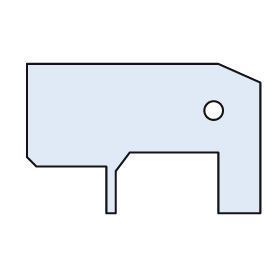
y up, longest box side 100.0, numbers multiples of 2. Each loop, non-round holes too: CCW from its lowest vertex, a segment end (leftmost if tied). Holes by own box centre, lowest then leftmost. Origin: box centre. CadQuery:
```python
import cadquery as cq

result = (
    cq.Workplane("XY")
    .moveTo(-16.0, -32.0)
    .lineTo(-12.0, -32.0)
    .lineTo(-12.0, -14.0)
    .lineTo(-6.0, -6.0)
    .lineTo(32.0, -6.0)
    .lineTo(32.0, -32.0)
    .lineTo(50.0, -32.0)
    .lineTo(50.0, 24.0)
    .lineTo(32.0, 32.0)
    .lineTo(-50.0, 32.0)
    .lineTo(-50.0, -8.0)
    .lineTo(-46.0, -12.0)
    .lineTo(-16.0, -12.0)
    .close()
    .moveTo(30.0, 12.0)
    .circle(4.0)
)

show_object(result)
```